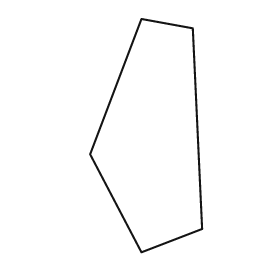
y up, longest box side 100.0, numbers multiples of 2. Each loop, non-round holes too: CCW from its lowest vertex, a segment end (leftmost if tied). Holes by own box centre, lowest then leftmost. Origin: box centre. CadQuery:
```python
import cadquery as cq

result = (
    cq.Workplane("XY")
    .moveTo(-2.0, -50.0)
    .lineTo(24.0, -40.0)
    .lineTo(20.0, 46.0)
    .lineTo(-2.0, 50.0)
    .lineTo(-24.0, -8.0)
    .close()
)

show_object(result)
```